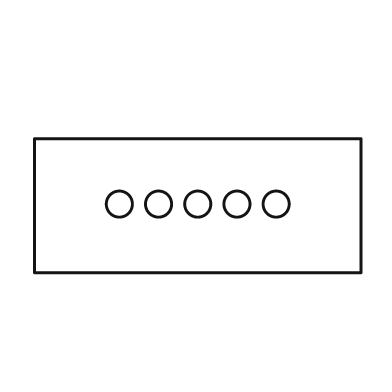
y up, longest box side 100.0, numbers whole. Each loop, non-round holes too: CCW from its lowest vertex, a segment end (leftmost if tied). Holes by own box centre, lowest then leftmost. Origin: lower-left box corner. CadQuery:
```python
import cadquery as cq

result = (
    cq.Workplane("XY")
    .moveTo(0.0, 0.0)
    .lineTo(100.0, 0.0)
    .lineTo(100.0, 41.0)
    .lineTo(0.0, 41.0)
    .close()
    .moveTo(26.0, 21.0)
    .circle(4.0)
    .moveTo(38.0, 21.0)
    .circle(4.0)
    .moveTo(50.0, 21.0)
    .circle(4.0)
    .moveTo(62.0, 21.0)
    .circle(4.0)
    .moveTo(74.0, 21.0)
    .circle(4.0)
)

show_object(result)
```